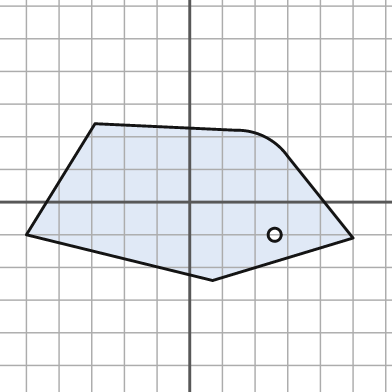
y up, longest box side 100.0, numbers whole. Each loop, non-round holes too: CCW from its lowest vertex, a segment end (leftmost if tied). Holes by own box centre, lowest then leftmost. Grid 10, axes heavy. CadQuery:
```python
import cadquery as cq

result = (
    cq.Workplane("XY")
    .moveTo(7.0, -24.0)
    .lineTo(50.0, -11.0)
    .lineTo(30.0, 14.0)
    .threePointArc((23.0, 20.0), (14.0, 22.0))
    .lineTo(-29.0, 24.0)
    .lineTo(-50.0, -10.0)
    .close()
    .moveTo(26.0, -10.0)
    .circle(2.0)
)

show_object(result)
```